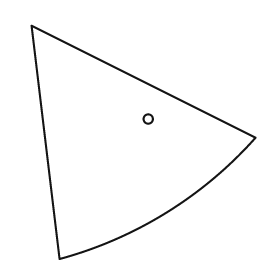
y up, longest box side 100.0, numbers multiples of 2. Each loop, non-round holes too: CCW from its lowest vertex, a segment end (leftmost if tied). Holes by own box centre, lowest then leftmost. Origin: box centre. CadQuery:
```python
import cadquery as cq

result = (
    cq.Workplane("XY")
    .moveTo(-36.0, -50.0)
    .threePointArc((10.0, -30.0), (48.0, 2.0))
    .lineTo(-48.0, 50.0)
    .close()
    .moveTo(2.0, 10.0)
    .circle(2.0)
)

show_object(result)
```